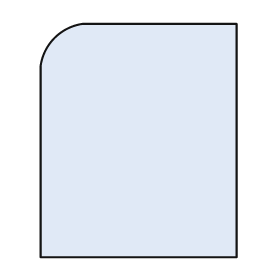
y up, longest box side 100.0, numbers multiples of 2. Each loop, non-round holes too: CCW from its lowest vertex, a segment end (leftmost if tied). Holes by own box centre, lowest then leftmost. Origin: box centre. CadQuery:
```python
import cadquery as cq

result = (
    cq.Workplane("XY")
    .moveTo(-42.0, -50.0)
    .lineTo(42.0, -50.0)
    .lineTo(42.0, 50.0)
    .lineTo(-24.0, 50.0)
    .threePointArc((-36.0, 44.0), (-42.0, 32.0))
    .close()
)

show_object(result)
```